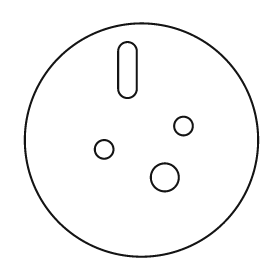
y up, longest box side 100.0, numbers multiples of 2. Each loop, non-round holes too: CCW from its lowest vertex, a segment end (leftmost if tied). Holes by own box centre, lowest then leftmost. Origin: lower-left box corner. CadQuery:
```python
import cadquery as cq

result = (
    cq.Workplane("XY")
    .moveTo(50.0, 50.0)
    .circle(50.0)
    .moveTo(60.0, 34.0)
    .circle(6.0)
    .moveTo(34.0, 46.0)
    .circle(4.0)
    .moveTo(68.0, 56.0)
    .circle(4.0)
    .moveTo(40.0, 72.0)
    .threePointArc((44.0, 68.0), (48.0, 72.0))
    .lineTo(48.0, 88.0)
    .threePointArc((44.0, 92.0), (40.0, 88.0))
    .close()
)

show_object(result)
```